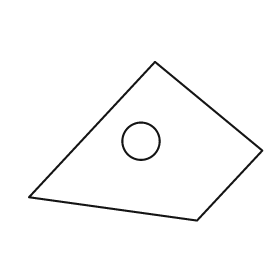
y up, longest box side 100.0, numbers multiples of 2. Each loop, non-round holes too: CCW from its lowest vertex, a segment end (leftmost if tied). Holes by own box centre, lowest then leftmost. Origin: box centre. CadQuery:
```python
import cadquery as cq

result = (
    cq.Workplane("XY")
    .moveTo(22.0, -34.0)
    .lineTo(50.0, -4.0)
    .lineTo(4.0, 34.0)
    .lineTo(-50.0, -24.0)
    .close()
    .moveTo(-2.0, 0.0)
    .circle(8.0)
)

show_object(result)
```